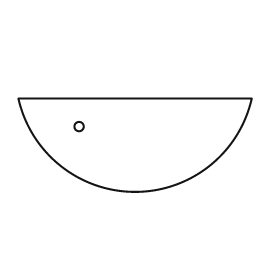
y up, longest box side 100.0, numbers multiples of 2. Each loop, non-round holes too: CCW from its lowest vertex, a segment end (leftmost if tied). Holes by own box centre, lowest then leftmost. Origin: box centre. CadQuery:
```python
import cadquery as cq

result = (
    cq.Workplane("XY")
    .moveTo(-50.0, 20.0)
    .threePointArc((0.0, -20.0), (50.0, 20.0))
    .close()
    .moveTo(-24.0, 8.0)
    .circle(2.0)
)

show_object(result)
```